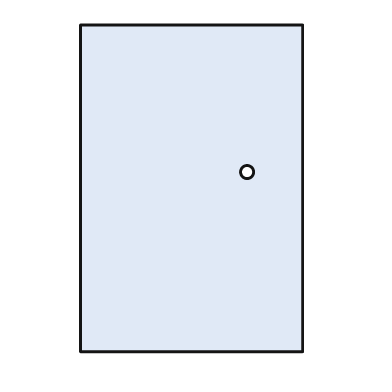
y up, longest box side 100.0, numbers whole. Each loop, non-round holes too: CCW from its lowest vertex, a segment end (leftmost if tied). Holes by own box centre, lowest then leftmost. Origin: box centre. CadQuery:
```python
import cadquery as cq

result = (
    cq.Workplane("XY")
    .moveTo(-34.0, -50.0)
    .lineTo(34.0, -50.0)
    .lineTo(34.0, 50.0)
    .lineTo(-34.0, 50.0)
    .close()
    .moveTo(17.0, 5.0)
    .circle(2.0)
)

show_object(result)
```